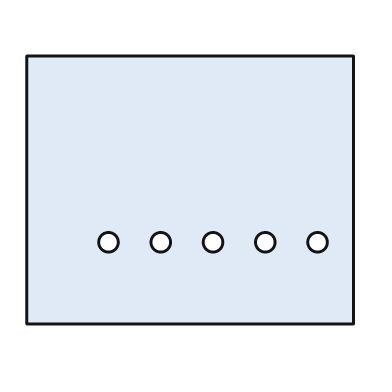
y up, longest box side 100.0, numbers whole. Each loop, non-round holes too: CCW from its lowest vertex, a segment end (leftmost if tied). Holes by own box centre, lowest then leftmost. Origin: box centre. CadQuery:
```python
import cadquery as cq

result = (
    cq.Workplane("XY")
    .moveTo(-50.0, -41.0)
    .lineTo(50.0, -41.0)
    .lineTo(50.0, 41.0)
    .lineTo(-50.0, 41.0)
    .close()
    .moveTo(-25.0, -16.0)
    .circle(3.0)
    .moveTo(-9.0, -16.0)
    .circle(3.0)
    .moveTo(7.0, -16.0)
    .circle(3.0)
    .moveTo(23.0, -16.0)
    .circle(3.0)
    .moveTo(39.0, -16.0)
    .circle(3.0)
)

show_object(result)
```